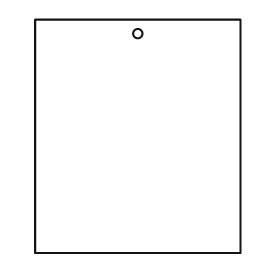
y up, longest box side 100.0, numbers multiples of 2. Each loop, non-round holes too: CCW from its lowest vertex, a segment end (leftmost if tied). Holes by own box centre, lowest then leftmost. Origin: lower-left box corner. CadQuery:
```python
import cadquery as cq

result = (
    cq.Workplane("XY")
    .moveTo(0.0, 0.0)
    .lineTo(88.0, 0.0)
    .lineTo(88.0, 100.0)
    .lineTo(0.0, 100.0)
    .close()
    .moveTo(44.0, 94.0)
    .circle(2.0)
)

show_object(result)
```